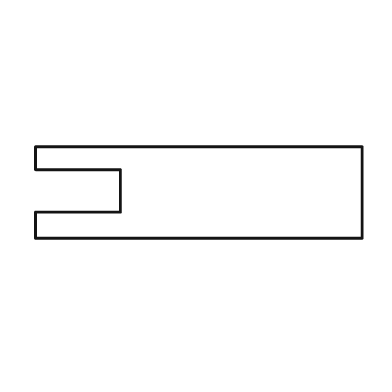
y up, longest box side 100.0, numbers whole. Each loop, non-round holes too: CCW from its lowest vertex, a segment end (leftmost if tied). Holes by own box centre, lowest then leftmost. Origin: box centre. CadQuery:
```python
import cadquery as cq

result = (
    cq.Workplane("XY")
    .moveTo(-50.0, -14.0)
    .lineTo(50.0, -14.0)
    .lineTo(50.0, 14.0)
    .lineTo(-50.0, 14.0)
    .lineTo(-50.0, 7.0)
    .lineTo(-24.0, 7.0)
    .lineTo(-24.0, -6.0)
    .lineTo(-50.0, -6.0)
    .close()
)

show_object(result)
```